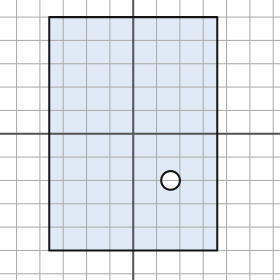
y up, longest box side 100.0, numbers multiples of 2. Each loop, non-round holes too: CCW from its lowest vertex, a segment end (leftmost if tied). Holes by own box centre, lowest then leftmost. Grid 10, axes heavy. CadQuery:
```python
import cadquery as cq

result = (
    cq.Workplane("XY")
    .moveTo(-36.0, -50.0)
    .lineTo(36.0, -50.0)
    .lineTo(36.0, 50.0)
    .lineTo(-36.0, 50.0)
    .close()
    .moveTo(16.0, -20.0)
    .circle(4.0)
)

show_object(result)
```